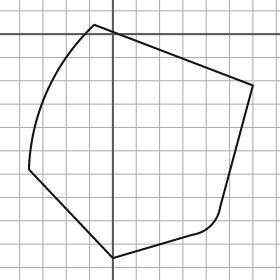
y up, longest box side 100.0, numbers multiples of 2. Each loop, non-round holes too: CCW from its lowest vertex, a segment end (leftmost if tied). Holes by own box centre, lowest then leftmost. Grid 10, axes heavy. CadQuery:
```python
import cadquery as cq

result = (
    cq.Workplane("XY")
    .moveTo(0.0, -96.0)
    .lineTo(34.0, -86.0)
    .threePointArc((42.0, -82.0), (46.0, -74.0))
    .lineTo(60.0, -22.0)
    .lineTo(-8.0, 4.0)
    .threePointArc((-28.0, -24.0), (-36.0, -58.0))
    .close()
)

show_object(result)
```